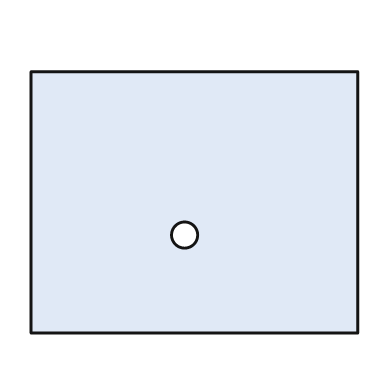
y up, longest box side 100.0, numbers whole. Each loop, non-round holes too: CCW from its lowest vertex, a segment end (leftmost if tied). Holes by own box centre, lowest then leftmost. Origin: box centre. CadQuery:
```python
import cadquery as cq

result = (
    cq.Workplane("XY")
    .moveTo(-50.0, -40.0)
    .lineTo(50.0, -40.0)
    .lineTo(50.0, 40.0)
    .lineTo(-50.0, 40.0)
    .close()
    .moveTo(-3.0, -10.0)
    .circle(4.0)
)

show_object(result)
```